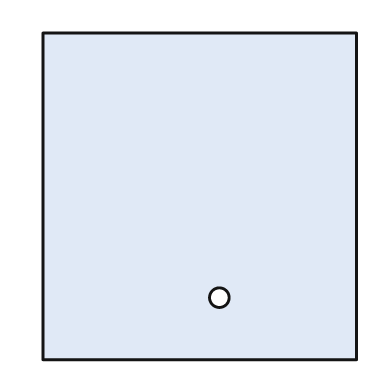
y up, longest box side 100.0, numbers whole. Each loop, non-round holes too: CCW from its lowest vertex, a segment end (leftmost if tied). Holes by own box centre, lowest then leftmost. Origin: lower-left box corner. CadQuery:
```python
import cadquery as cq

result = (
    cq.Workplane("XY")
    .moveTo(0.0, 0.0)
    .lineTo(96.0, 0.0)
    .lineTo(96.0, 100.0)
    .lineTo(0.0, 100.0)
    .close()
    .moveTo(54.0, 19.0)
    .circle(3.0)
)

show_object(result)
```